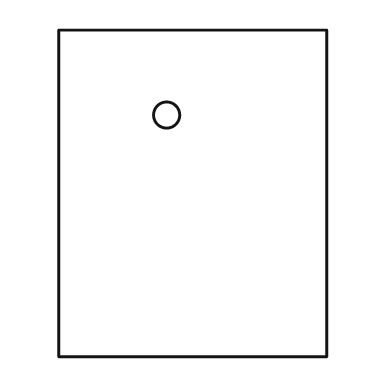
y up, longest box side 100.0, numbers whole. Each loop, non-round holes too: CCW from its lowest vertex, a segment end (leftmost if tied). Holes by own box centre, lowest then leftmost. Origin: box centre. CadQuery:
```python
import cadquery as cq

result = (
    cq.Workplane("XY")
    .moveTo(-41.0, -50.0)
    .lineTo(41.0, -50.0)
    .lineTo(41.0, 50.0)
    .lineTo(-41.0, 50.0)
    .close()
    .moveTo(-8.0, 24.0)
    .circle(4.0)
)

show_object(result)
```